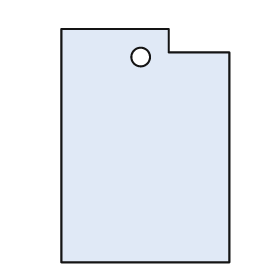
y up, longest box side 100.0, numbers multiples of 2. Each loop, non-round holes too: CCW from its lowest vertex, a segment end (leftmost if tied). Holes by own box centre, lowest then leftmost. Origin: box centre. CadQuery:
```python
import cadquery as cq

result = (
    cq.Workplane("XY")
    .moveTo(-36.0, -50.0)
    .lineTo(36.0, -50.0)
    .lineTo(36.0, 40.0)
    .lineTo(10.0, 40.0)
    .lineTo(10.0, 50.0)
    .lineTo(-36.0, 50.0)
    .close()
    .moveTo(-2.0, 38.0)
    .circle(4.0)
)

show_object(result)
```